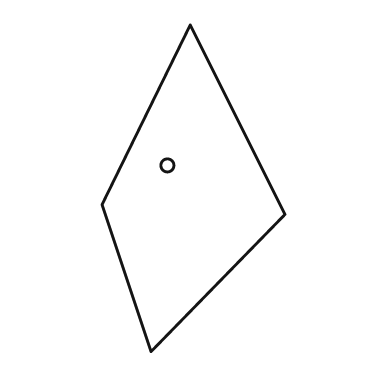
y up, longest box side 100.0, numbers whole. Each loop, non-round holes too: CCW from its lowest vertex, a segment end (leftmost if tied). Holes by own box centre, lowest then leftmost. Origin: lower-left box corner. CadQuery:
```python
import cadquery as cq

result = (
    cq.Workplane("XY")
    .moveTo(15.0, 0.0)
    .lineTo(56.0, 42.0)
    .lineTo(27.0, 100.0)
    .lineTo(0.0, 45.0)
    .close()
    .moveTo(20.0, 57.0)
    .circle(2.0)
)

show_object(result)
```